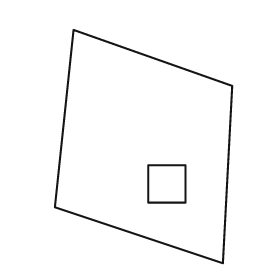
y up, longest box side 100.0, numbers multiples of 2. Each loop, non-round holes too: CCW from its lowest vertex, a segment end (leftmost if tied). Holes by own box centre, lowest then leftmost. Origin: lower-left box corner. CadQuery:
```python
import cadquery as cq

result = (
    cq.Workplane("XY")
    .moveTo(72.0, 0.0)
    .lineTo(76.0, 76.0)
    .lineTo(8.0, 100.0)
    .lineTo(0.0, 24.0)
    .close()
    .moveTo(40.0, 26.0)
    .lineTo(56.0, 26.0)
    .lineTo(56.0, 42.0)
    .lineTo(40.0, 42.0)
    .close()
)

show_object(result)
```